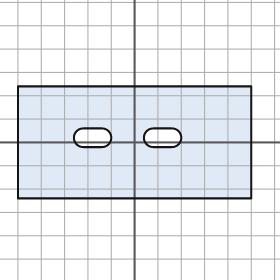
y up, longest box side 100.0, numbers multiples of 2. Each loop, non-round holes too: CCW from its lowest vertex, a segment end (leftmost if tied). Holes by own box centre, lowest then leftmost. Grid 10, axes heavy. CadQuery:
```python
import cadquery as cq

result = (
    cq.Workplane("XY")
    .moveTo(-50.0, -24.0)
    .lineTo(50.0, -24.0)
    .lineTo(50.0, 24.0)
    .lineTo(-50.0, 24.0)
    .close()
    .moveTo(-22.0, -2.0)
    .lineTo(-14.0, -2.0)
    .threePointArc((-10.0, 2.0), (-14.0, 6.0))
    .lineTo(-22.0, 6.0)
    .threePointArc((-26.0, 2.0), (-22.0, -2.0))
    .close()
    .moveTo(8.0, -2.0)
    .lineTo(16.0, -2.0)
    .threePointArc((20.0, 2.0), (16.0, 6.0))
    .lineTo(8.0, 6.0)
    .threePointArc((4.0, 2.0), (8.0, -2.0))
    .close()
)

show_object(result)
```